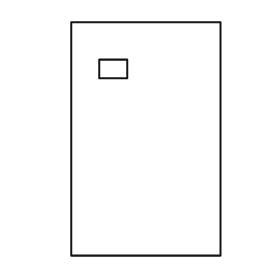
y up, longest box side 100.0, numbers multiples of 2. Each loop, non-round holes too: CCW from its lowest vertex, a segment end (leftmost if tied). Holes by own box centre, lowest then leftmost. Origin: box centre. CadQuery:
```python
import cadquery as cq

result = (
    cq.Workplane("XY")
    .moveTo(-32.0, -50.0)
    .lineTo(32.0, -50.0)
    .lineTo(32.0, 50.0)
    .lineTo(-32.0, 50.0)
    .close()
    .moveTo(-20.0, 26.0)
    .lineTo(-8.0, 26.0)
    .lineTo(-8.0, 34.0)
    .lineTo(-20.0, 34.0)
    .close()
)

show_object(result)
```